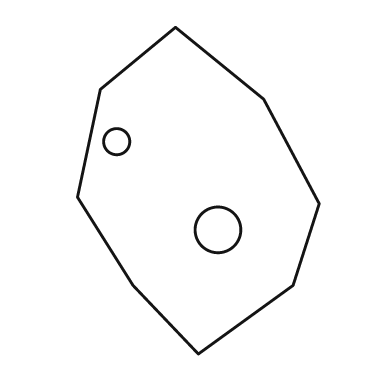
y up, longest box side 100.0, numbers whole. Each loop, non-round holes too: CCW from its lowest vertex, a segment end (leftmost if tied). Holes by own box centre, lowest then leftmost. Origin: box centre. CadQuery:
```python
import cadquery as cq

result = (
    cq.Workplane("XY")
    .moveTo(0.0, -50.0)
    .lineTo(29.0, -29.0)
    .lineTo(37.0, -4.0)
    .lineTo(20.0, 28.0)
    .lineTo(-7.0, 50.0)
    .lineTo(-30.0, 31.0)
    .lineTo(-37.0, -2.0)
    .lineTo(-20.0, -29.0)
    .close()
    .moveTo(6.0, -12.0)
    .circle(7.0)
    .moveTo(-25.0, 15.0)
    .circle(4.0)
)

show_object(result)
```